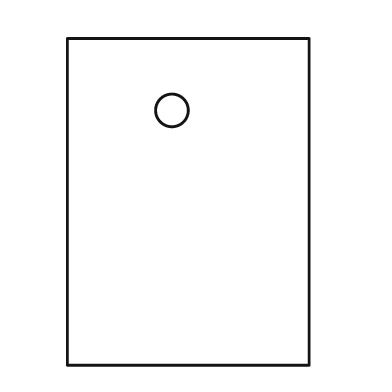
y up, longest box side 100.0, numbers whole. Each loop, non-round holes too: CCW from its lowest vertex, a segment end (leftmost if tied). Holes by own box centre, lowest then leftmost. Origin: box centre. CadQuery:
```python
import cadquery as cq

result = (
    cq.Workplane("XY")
    .moveTo(-37.0, -50.0)
    .lineTo(37.0, -50.0)
    .lineTo(37.0, 50.0)
    .lineTo(-37.0, 50.0)
    .close()
    .moveTo(-5.0, 28.0)
    .circle(5.0)
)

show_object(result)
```